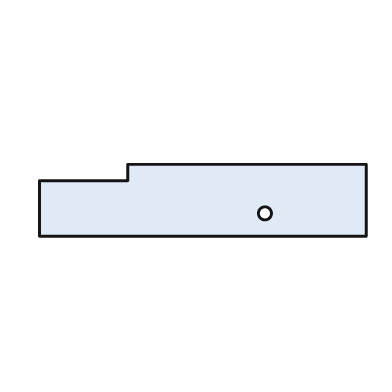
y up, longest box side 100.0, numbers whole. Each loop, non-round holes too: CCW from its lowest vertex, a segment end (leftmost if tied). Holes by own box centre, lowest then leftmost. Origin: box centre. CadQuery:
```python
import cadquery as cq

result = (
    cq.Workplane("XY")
    .moveTo(-50.0, -11.0)
    .lineTo(50.0, -11.0)
    .lineTo(50.0, 11.0)
    .lineTo(-23.0, 11.0)
    .lineTo(-23.0, 6.0)
    .lineTo(-50.0, 6.0)
    .close()
    .moveTo(19.0, -4.0)
    .circle(2.0)
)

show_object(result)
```